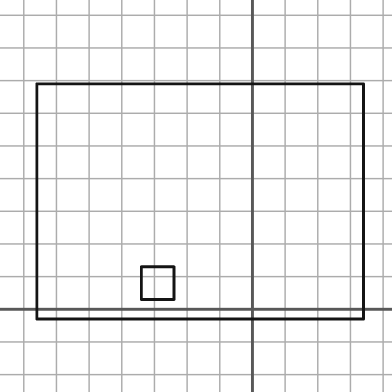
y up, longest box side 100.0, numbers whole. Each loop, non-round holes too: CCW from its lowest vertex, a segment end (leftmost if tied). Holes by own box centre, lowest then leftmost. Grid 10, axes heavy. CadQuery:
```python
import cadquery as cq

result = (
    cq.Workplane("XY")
    .moveTo(-66.0, -3.0)
    .lineTo(34.0, -3.0)
    .lineTo(34.0, 69.0)
    .lineTo(-66.0, 69.0)
    .close()
    .moveTo(-34.0, 3.0)
    .lineTo(-24.0, 3.0)
    .lineTo(-24.0, 13.0)
    .lineTo(-34.0, 13.0)
    .close()
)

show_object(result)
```